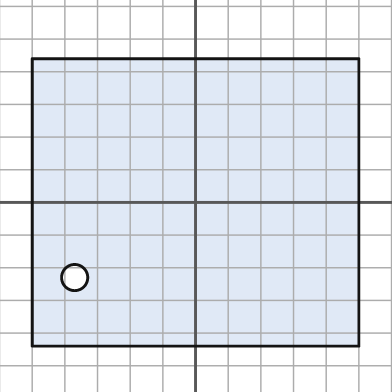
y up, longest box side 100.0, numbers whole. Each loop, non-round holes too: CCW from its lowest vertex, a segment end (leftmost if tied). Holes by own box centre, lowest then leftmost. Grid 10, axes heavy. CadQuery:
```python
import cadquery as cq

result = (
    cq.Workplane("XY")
    .moveTo(-50.0, -44.0)
    .lineTo(50.0, -44.0)
    .lineTo(50.0, 44.0)
    .lineTo(-50.0, 44.0)
    .close()
    .moveTo(-37.0, -23.0)
    .circle(4.0)
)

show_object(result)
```